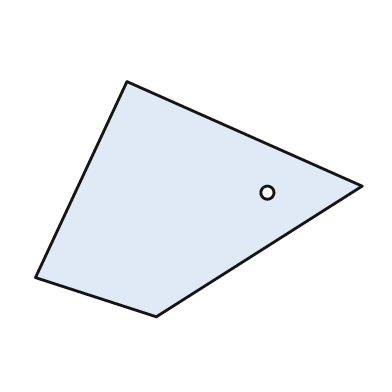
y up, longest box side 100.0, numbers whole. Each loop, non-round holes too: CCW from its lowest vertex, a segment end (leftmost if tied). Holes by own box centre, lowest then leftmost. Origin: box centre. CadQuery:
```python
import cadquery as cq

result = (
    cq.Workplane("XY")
    .moveTo(-13.0, -36.0)
    .lineTo(50.0, 4.0)
    .lineTo(-22.0, 36.0)
    .lineTo(-50.0, -24.0)
    .close()
    .moveTo(21.0, 2.0)
    .circle(2.0)
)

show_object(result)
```